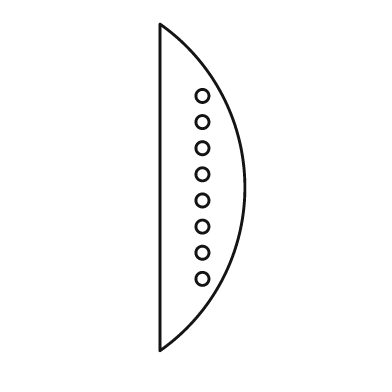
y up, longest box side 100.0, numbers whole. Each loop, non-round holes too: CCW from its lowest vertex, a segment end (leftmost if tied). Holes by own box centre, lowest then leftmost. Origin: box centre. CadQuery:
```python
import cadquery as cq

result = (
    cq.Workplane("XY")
    .moveTo(-13.0, -50.0)
    .threePointArc((13.0, 0.0), (-13.0, 50.0))
    .close()
    .moveTo(0.0, -28.0)
    .circle(2.0)
    .moveTo(0.0, -20.0)
    .circle(2.0)
    .moveTo(0.0, -12.0)
    .circle(2.0)
    .moveTo(0.0, -4.0)
    .circle(2.0)
    .moveTo(0.0, 4.0)
    .circle(2.0)
    .moveTo(0.0, 12.0)
    .circle(2.0)
    .moveTo(0.0, 20.0)
    .circle(2.0)
    .moveTo(0.0, 28.0)
    .circle(2.0)
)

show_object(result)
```